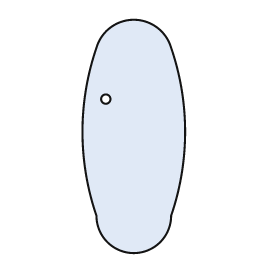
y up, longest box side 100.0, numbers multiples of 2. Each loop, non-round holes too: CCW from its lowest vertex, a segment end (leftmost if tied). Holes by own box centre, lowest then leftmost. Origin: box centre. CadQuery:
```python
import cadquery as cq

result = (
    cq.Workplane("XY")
    .moveTo(-16.0, -34.0)
    .threePointArc((0.0, -50.0), (16.0, -34.0))
    .threePointArc((22.0, 2.0), (16.0, 38.0))
    .threePointArc((0.0, 50.0), (-16.0, 38.0))
    .threePointArc((-22.0, 2.0), (-16.0, -34.0))
    .close()
    .moveTo(-12.0, 16.0)
    .circle(2.0)
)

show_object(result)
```